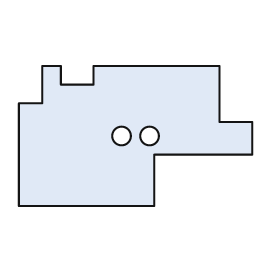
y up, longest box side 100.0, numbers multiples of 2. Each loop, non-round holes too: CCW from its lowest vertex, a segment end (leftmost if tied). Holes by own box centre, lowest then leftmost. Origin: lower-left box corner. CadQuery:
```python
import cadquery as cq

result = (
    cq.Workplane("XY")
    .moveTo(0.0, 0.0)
    .lineTo(58.0, 0.0)
    .lineTo(58.0, 22.0)
    .lineTo(100.0, 22.0)
    .lineTo(100.0, 36.0)
    .lineTo(86.0, 36.0)
    .lineTo(86.0, 60.0)
    .lineTo(32.0, 60.0)
    .lineTo(32.0, 52.0)
    .lineTo(18.0, 52.0)
    .lineTo(18.0, 60.0)
    .lineTo(10.0, 60.0)
    .lineTo(10.0, 44.0)
    .lineTo(0.0, 44.0)
    .close()
    .moveTo(44.0, 30.0)
    .circle(4.0)
    .moveTo(56.0, 30.0)
    .circle(4.0)
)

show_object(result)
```